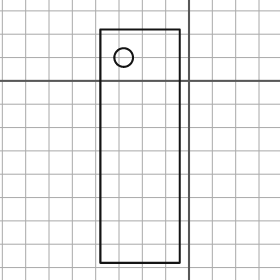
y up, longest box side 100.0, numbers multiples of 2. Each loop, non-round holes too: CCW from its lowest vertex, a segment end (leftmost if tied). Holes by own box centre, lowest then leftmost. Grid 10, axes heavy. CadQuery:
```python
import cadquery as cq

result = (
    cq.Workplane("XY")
    .moveTo(-38.0, -78.0)
    .lineTo(-4.0, -78.0)
    .lineTo(-4.0, 22.0)
    .lineTo(-38.0, 22.0)
    .close()
    .moveTo(-28.0, 10.0)
    .circle(4.0)
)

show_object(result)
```